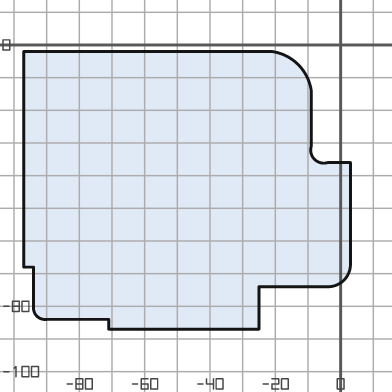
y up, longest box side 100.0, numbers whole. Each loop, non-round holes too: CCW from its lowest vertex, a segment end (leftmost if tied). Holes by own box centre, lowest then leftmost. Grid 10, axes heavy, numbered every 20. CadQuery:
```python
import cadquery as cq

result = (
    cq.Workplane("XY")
    .moveTo(-71.0, -87.0)
    .lineTo(-25.0, -87.0)
    .lineTo(-25.0, -74.0)
    .lineTo(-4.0, -74.0)
    .threePointArc((1.0, -72.0), (3.0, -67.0))
    .lineTo(3.0, -36.0)
    .lineTo(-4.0, -36.0)
    .threePointArc((-8.0, -35.0), (-9.0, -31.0))
    .lineTo(-9.0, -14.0)
    .threePointArc((-13.0, -6.0), (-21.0, -2.0))
    .lineTo(-97.0, -2.0)
    .lineTo(-97.0, -68.0)
    .lineTo(-94.0, -68.0)
    .lineTo(-94.0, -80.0)
    .threePointArc((-93.0, -83.0), (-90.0, -84.0))
    .lineTo(-71.0, -84.0)
    .close()
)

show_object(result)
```